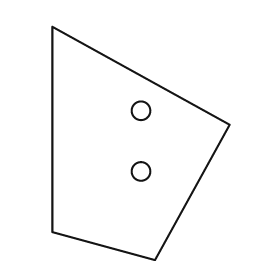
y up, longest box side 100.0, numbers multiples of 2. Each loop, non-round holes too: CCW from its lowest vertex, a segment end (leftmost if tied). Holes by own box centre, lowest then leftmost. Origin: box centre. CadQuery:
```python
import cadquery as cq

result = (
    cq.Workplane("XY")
    .moveTo(6.0, -50.0)
    .lineTo(38.0, 8.0)
    .lineTo(-38.0, 50.0)
    .lineTo(-38.0, -38.0)
    .close()
    .moveTo(0.0, -12.0)
    .circle(4.0)
    .moveTo(0.0, 14.0)
    .circle(4.0)
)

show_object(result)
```